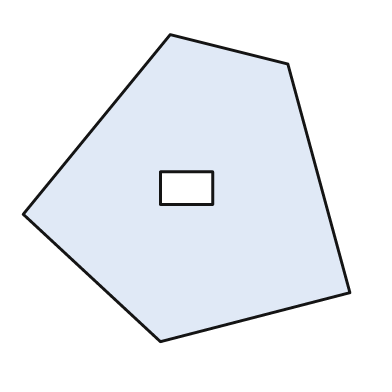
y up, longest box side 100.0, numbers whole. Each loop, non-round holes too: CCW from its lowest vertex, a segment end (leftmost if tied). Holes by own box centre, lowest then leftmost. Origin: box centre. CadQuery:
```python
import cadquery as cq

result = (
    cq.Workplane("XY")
    .moveTo(-8.0, -47.0)
    .lineTo(50.0, -32.0)
    .lineTo(31.0, 38.0)
    .lineTo(-5.0, 47.0)
    .lineTo(-50.0, -8.0)
    .close()
    .moveTo(-8.0, -5.0)
    .lineTo(8.0, -5.0)
    .lineTo(8.0, 5.0)
    .lineTo(-8.0, 5.0)
    .close()
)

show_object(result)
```